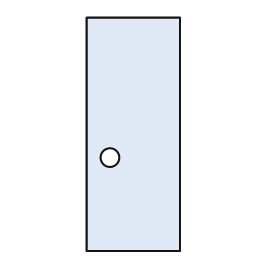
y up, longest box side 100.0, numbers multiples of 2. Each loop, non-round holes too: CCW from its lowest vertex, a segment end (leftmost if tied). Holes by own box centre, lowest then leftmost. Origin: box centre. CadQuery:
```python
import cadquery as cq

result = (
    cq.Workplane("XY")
    .moveTo(-20.0, -50.0)
    .lineTo(20.0, -50.0)
    .lineTo(20.0, 50.0)
    .lineTo(-20.0, 50.0)
    .close()
    .moveTo(-10.0, -10.0)
    .circle(4.0)
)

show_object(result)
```